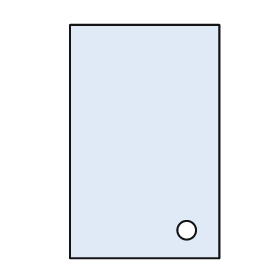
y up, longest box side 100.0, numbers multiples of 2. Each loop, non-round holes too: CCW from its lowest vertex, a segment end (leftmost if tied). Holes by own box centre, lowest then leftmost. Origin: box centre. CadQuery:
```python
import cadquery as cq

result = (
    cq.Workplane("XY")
    .moveTo(-32.0, -50.0)
    .lineTo(32.0, -50.0)
    .lineTo(32.0, 50.0)
    .lineTo(-32.0, 50.0)
    .close()
    .moveTo(18.0, -38.0)
    .circle(4.0)
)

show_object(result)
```